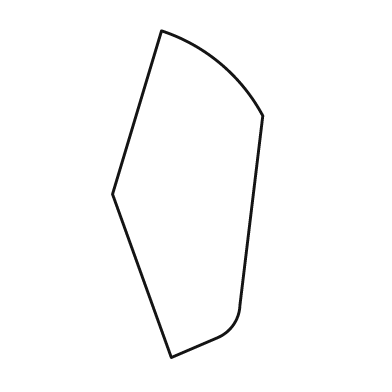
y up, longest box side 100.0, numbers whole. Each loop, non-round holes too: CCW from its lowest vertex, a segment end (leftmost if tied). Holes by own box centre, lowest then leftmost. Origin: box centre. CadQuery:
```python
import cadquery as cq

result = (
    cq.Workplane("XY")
    .moveTo(-5.0, -50.0)
    .lineTo(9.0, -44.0)
    .threePointArc((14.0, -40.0), (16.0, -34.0))
    .lineTo(23.0, 24.0)
    .threePointArc((10.0, 40.0), (-8.0, 50.0))
    .lineTo(-23.0, 0.0)
    .close()
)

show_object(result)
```